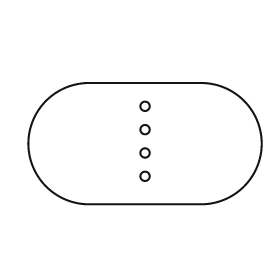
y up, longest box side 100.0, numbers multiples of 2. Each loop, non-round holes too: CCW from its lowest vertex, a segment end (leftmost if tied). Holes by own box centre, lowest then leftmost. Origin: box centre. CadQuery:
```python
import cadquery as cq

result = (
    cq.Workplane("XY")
    .moveTo(-24.0, -26.0)
    .lineTo(24.0, -26.0)
    .threePointArc((50.0, 0.0), (24.0, 26.0))
    .lineTo(-24.0, 26.0)
    .threePointArc((-50.0, 0.0), (-24.0, -26.0))
    .close()
    .moveTo(0.0, -14.0)
    .circle(2.0)
    .moveTo(0.0, -4.0)
    .circle(2.0)
    .moveTo(0.0, 6.0)
    .circle(2.0)
    .moveTo(0.0, 16.0)
    .circle(2.0)
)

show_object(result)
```